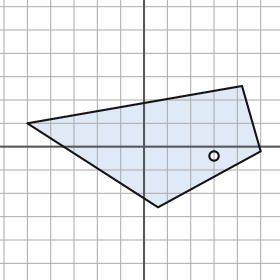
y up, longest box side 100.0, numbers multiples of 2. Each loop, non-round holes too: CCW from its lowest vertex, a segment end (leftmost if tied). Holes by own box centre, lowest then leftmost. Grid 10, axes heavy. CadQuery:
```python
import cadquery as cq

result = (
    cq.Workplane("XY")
    .moveTo(6.0, -26.0)
    .lineTo(50.0, -2.0)
    .lineTo(42.0, 26.0)
    .lineTo(-50.0, 10.0)
    .close()
    .moveTo(30.0, -4.0)
    .circle(2.0)
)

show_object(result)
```